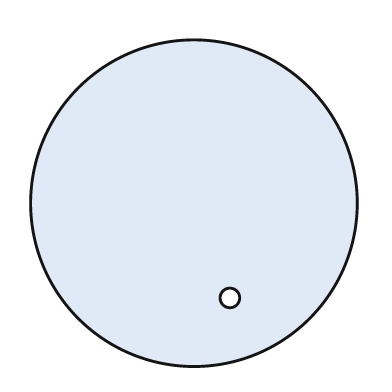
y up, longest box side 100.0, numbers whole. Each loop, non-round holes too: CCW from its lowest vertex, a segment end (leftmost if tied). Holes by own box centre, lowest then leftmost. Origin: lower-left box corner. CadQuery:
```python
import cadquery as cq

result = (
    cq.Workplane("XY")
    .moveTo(50.0, 50.0)
    .circle(50.0)
    .moveTo(61.0, 21.0)
    .circle(3.0)
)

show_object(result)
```